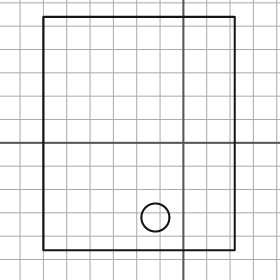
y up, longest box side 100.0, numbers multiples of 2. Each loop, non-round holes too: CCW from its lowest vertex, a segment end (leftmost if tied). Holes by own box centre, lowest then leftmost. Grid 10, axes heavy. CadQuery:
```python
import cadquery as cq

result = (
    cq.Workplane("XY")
    .moveTo(-60.0, -46.0)
    .lineTo(22.0, -46.0)
    .lineTo(22.0, 54.0)
    .lineTo(-60.0, 54.0)
    .close()
    .moveTo(-12.0, -32.0)
    .circle(6.0)
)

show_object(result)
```